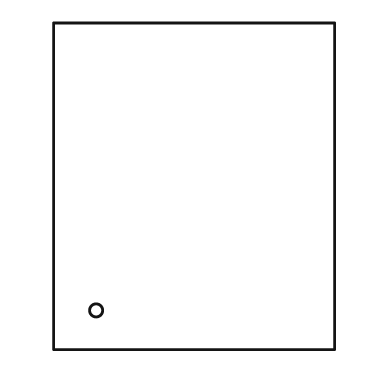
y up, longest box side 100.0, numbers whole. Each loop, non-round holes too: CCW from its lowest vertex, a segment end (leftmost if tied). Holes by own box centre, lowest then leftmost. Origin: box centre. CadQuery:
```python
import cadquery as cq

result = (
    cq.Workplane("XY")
    .moveTo(-43.0, -50.0)
    .lineTo(43.0, -50.0)
    .lineTo(43.0, 50.0)
    .lineTo(-43.0, 50.0)
    .close()
    .moveTo(-30.0, -38.0)
    .circle(2.0)
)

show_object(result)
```